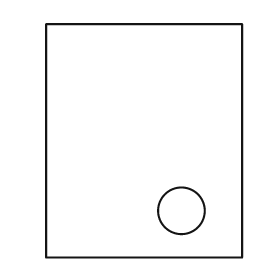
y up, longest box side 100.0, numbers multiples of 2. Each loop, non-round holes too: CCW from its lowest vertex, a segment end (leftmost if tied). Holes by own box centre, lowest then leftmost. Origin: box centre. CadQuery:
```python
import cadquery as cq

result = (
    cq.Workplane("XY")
    .moveTo(-42.0, -50.0)
    .lineTo(42.0, -50.0)
    .lineTo(42.0, 50.0)
    .lineTo(-42.0, 50.0)
    .close()
    .moveTo(16.0, -30.0)
    .circle(10.0)
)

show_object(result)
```